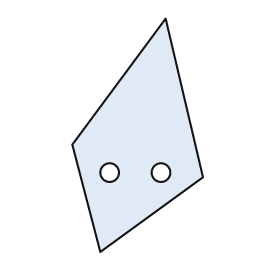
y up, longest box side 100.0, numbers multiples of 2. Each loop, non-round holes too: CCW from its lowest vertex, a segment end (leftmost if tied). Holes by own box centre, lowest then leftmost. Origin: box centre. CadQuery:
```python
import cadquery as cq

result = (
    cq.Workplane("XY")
    .moveTo(-16.0, -50.0)
    .lineTo(28.0, -18.0)
    .lineTo(12.0, 50.0)
    .lineTo(-28.0, -4.0)
    .close()
    .moveTo(-12.0, -16.0)
    .circle(4.0)
    .moveTo(10.0, -16.0)
    .circle(4.0)
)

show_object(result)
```